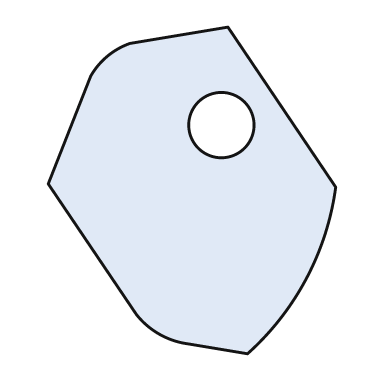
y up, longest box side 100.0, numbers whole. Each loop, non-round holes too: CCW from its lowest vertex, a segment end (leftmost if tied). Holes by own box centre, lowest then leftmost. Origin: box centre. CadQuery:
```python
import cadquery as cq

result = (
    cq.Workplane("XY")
    .moveTo(17.0, -50.0)
    .threePointArc((35.0, -27.0), (44.0, 1.0))
    .lineTo(11.0, 50.0)
    .lineTo(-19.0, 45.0)
    .threePointArc((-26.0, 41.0), (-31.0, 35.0))
    .lineTo(-44.0, 2.0)
    .lineTo(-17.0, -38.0)
    .threePointArc((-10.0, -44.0), (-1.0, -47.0))
    .close()
    .moveTo(9.0, 20.0)
    .circle(10.0)
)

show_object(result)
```